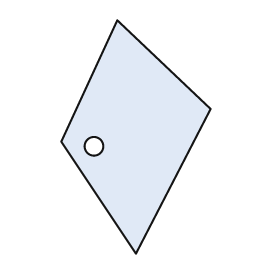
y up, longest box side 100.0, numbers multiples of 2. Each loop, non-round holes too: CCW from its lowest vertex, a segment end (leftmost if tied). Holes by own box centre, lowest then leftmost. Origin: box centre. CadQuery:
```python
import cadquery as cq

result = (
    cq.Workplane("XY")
    .moveTo(0.0, -50.0)
    .lineTo(32.0, 12.0)
    .lineTo(-8.0, 50.0)
    .lineTo(-32.0, -2.0)
    .close()
    .moveTo(-18.0, -4.0)
    .circle(4.0)
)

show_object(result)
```